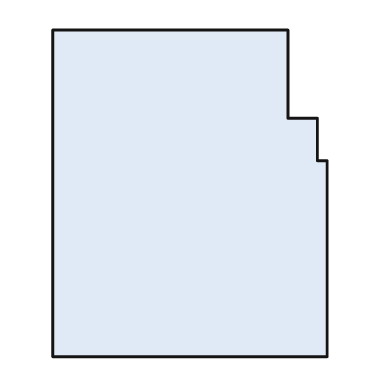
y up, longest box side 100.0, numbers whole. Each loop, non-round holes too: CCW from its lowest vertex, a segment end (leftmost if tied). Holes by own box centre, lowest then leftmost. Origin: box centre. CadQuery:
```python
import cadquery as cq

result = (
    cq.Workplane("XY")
    .moveTo(-42.0, -50.0)
    .lineTo(42.0, -50.0)
    .lineTo(42.0, 10.0)
    .lineTo(39.0, 10.0)
    .lineTo(39.0, 23.0)
    .lineTo(30.0, 23.0)
    .lineTo(30.0, 50.0)
    .lineTo(-42.0, 50.0)
    .close()
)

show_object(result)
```